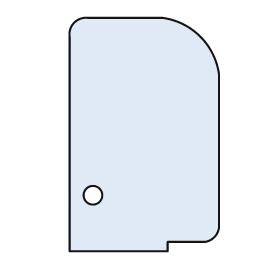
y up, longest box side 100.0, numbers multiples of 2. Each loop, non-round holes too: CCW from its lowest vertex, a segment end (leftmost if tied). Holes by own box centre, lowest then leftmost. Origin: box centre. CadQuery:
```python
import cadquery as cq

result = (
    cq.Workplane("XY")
    .moveTo(-32.0, -50.0)
    .lineTo(10.0, -50.0)
    .lineTo(10.0, -46.0)
    .lineTo(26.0, -46.0)
    .threePointArc((30.0, -44.0), (32.0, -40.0))
    .lineTo(32.0, 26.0)
    .threePointArc((24.0, 42.0), (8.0, 50.0))
    .lineTo(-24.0, 50.0)
    .threePointArc((-30.0, 48.0), (-32.0, 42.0))
    .close()
    .moveTo(-22.0, -26.0)
    .circle(4.0)
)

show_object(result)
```